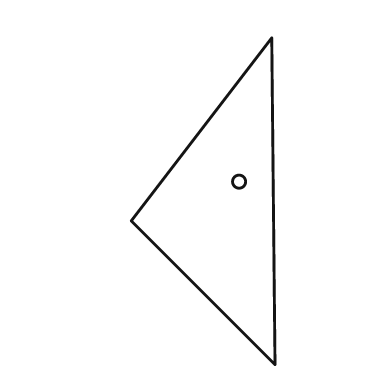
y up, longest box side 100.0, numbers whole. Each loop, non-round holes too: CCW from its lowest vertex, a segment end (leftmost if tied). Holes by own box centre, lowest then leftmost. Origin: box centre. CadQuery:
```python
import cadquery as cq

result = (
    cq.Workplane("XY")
    .moveTo(22.0, -50.0)
    .lineTo(21.0, 50.0)
    .lineTo(-22.0, -6.0)
    .close()
    .moveTo(11.0, 6.0)
    .circle(2.0)
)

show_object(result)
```